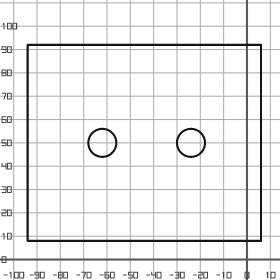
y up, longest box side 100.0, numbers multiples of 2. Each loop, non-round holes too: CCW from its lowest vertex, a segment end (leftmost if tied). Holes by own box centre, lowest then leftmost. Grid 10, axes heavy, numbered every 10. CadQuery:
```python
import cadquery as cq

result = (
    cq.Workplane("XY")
    .moveTo(-94.0, 8.0)
    .lineTo(6.0, 8.0)
    .lineTo(6.0, 92.0)
    .lineTo(-94.0, 92.0)
    .close()
    .moveTo(-62.0, 50.0)
    .circle(6.0)
    .moveTo(-24.0, 50.0)
    .circle(6.0)
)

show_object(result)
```